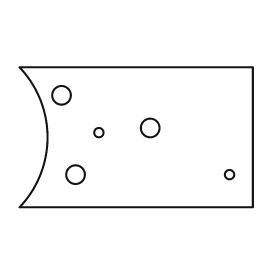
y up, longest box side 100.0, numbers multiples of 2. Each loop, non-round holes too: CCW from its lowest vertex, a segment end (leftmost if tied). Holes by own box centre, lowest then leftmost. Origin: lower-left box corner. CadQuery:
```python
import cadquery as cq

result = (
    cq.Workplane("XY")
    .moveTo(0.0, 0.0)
    .lineTo(100.0, 0.0)
    .lineTo(100.0, 60.0)
    .lineTo(0.0, 60.0)
    .threePointArc((12.0, 30.0), (0.0, 0.0))
    .close()
    .moveTo(24.0, 14.0)
    .circle(4.0)
    .moveTo(90.0, 14.0)
    .circle(2.0)
    .moveTo(34.0, 32.0)
    .circle(2.0)
    .moveTo(56.0, 34.0)
    .circle(4.0)
    .moveTo(18.0, 48.0)
    .circle(4.0)
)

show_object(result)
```